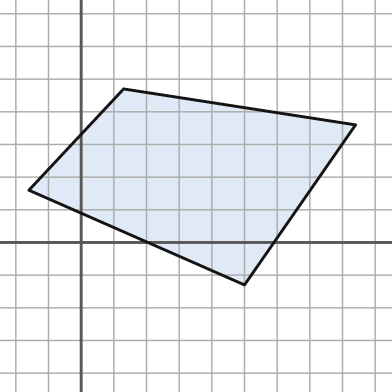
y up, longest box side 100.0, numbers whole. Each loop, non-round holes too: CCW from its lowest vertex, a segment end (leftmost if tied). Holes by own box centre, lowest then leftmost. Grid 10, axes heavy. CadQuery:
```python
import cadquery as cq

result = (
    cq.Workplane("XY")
    .moveTo(50.0, -13.0)
    .lineTo(84.0, 36.0)
    .lineTo(13.0, 47.0)
    .lineTo(-16.0, 16.0)
    .close()
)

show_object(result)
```